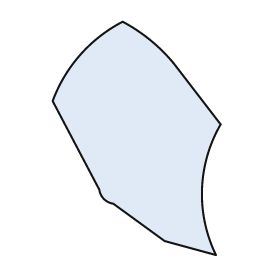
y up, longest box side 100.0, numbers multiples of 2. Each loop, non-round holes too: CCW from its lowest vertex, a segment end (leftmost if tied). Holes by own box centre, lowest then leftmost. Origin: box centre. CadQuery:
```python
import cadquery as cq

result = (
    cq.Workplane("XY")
    .moveTo(34.0, -50.0)
    .threePointArc((28.0, -22.0), (36.0, 6.0))
    .lineTo(16.0, 32.0)
    .threePointArc((6.0, 42.0), (-6.0, 50.0))
    .threePointArc((-24.0, 36.0), (-36.0, 16.0))
    .lineTo(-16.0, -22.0)
    .threePointArc((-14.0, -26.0), (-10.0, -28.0))
    .lineTo(12.0, -44.0)
    .close()
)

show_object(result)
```